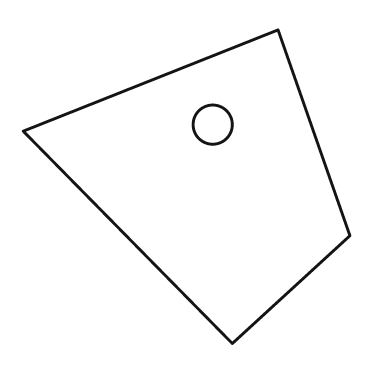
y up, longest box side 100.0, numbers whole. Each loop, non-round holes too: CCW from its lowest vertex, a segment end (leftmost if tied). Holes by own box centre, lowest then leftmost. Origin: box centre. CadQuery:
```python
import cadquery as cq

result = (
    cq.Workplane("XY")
    .moveTo(14.0, -48.0)
    .lineTo(50.0, -15.0)
    .lineTo(28.0, 48.0)
    .lineTo(-50.0, 17.0)
    .close()
    .moveTo(8.0, 19.0)
    .circle(6.0)
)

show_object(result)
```